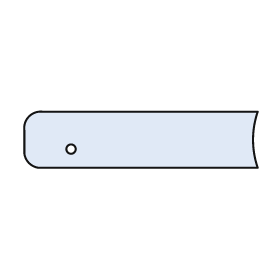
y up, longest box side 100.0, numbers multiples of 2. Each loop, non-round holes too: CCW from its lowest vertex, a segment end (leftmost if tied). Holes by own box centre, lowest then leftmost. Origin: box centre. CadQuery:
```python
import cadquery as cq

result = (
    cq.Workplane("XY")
    .moveTo(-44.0, -12.0)
    .lineTo(50.0, -12.0)
    .threePointArc((48.0, 0.0), (50.0, 12.0))
    .lineTo(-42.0, 12.0)
    .threePointArc((-48.0, 10.0), (-50.0, 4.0))
    .lineTo(-50.0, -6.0)
    .threePointArc((-48.0, -10.0), (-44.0, -12.0))
    .close()
    .moveTo(-30.0, -4.0)
    .circle(2.0)
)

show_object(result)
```